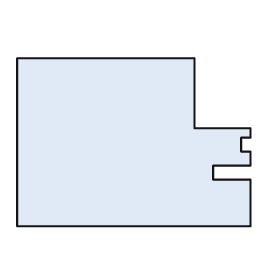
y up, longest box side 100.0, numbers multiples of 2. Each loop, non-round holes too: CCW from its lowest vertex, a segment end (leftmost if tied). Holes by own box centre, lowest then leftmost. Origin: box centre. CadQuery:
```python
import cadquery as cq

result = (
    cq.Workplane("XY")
    .moveTo(-50.0, -36.0)
    .lineTo(50.0, -36.0)
    .lineTo(50.0, -16.0)
    .lineTo(34.0, -16.0)
    .lineTo(34.0, -10.0)
    .lineTo(50.0, -10.0)
    .lineTo(50.0, -4.0)
    .lineTo(46.0, -4.0)
    .lineTo(46.0, 2.0)
    .lineTo(50.0, 2.0)
    .lineTo(50.0, 6.0)
    .lineTo(26.0, 6.0)
    .lineTo(26.0, 36.0)
    .lineTo(-50.0, 36.0)
    .close()
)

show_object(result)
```